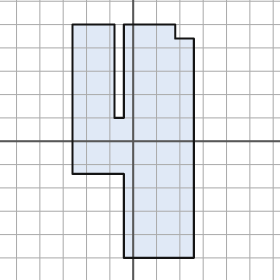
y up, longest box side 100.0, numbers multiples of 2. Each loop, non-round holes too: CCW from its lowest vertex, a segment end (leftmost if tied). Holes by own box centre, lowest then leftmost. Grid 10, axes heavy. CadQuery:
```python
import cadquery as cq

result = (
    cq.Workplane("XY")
    .moveTo(-4.0, -50.0)
    .lineTo(26.0, -50.0)
    .lineTo(26.0, 44.0)
    .lineTo(18.0, 44.0)
    .lineTo(18.0, 50.0)
    .lineTo(-4.0, 50.0)
    .lineTo(-4.0, 10.0)
    .lineTo(-8.0, 10.0)
    .lineTo(-8.0, 50.0)
    .lineTo(-26.0, 50.0)
    .lineTo(-26.0, -14.0)
    .lineTo(-4.0, -14.0)
    .close()
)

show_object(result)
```